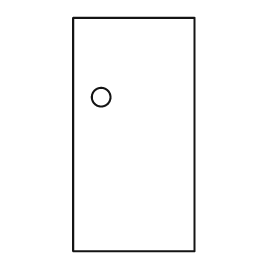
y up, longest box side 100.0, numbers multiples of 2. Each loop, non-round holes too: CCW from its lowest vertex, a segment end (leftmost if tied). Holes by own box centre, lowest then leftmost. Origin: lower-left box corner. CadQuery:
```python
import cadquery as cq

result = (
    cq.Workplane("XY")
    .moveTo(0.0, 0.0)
    .lineTo(52.0, 0.0)
    .lineTo(52.0, 100.0)
    .lineTo(0.0, 100.0)
    .close()
    .moveTo(12.0, 66.0)
    .circle(4.0)
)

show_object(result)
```